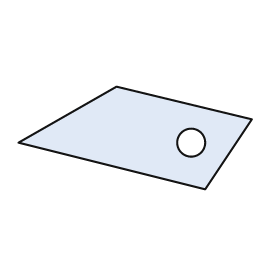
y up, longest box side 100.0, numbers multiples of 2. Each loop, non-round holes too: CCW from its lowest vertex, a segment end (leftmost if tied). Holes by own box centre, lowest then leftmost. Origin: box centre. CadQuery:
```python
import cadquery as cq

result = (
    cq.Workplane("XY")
    .moveTo(30.0, -22.0)
    .lineTo(50.0, 8.0)
    .lineTo(-8.0, 22.0)
    .lineTo(-50.0, -2.0)
    .close()
    .moveTo(24.0, -2.0)
    .circle(6.0)
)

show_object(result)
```